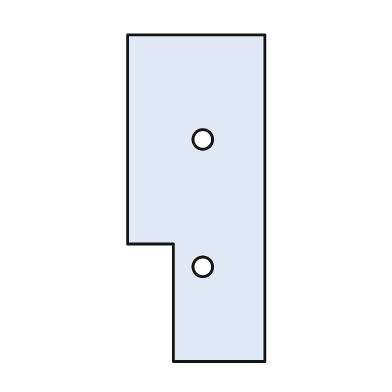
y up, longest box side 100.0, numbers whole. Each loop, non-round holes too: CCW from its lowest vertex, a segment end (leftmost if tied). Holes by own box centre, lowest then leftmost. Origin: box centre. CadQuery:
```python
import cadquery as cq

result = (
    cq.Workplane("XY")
    .moveTo(-7.0, -50.0)
    .lineTo(21.0, -50.0)
    .lineTo(21.0, 50.0)
    .lineTo(-21.0, 50.0)
    .lineTo(-21.0, -14.0)
    .lineTo(-7.0, -14.0)
    .close()
    .moveTo(2.0, -21.0)
    .circle(3.0)
    .moveTo(2.0, 18.0)
    .circle(3.0)
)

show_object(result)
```